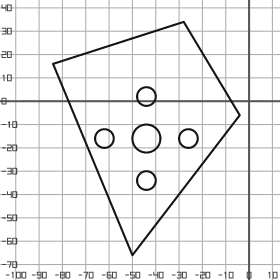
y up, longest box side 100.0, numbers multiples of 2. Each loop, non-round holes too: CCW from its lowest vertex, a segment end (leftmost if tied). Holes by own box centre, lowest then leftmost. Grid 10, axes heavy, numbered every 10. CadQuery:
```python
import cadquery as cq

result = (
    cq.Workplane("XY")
    .moveTo(-50.0, -66.0)
    .lineTo(-4.0, -6.0)
    .lineTo(-28.0, 34.0)
    .lineTo(-84.0, 16.0)
    .close()
    .moveTo(-44.0, -34.0)
    .circle(4.0)
    .moveTo(-62.0, -16.0)
    .circle(4.0)
    .moveTo(-44.0, -16.0)
    .circle(6.0)
    .moveTo(-26.0, -16.0)
    .circle(4.0)
    .moveTo(-44.0, 2.0)
    .circle(4.0)
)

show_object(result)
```